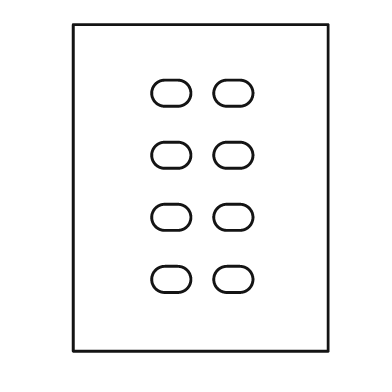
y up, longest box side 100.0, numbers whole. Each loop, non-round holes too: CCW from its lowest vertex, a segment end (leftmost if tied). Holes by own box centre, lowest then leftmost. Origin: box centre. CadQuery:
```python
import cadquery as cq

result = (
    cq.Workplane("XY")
    .moveTo(-39.0, -50.0)
    .lineTo(39.0, -50.0)
    .lineTo(39.0, 50.0)
    .lineTo(-39.0, 50.0)
    .close()
    .moveTo(-11.0, -32.0)
    .lineTo(-7.0, -32.0)
    .threePointArc((-3.0, -28.0), (-7.0, -24.0))
    .lineTo(-11.0, -24.0)
    .threePointArc((-15.0, -28.0), (-11.0, -32.0))
    .close()
    .moveTo(8.0, -32.0)
    .lineTo(12.0, -32.0)
    .threePointArc((16.0, -28.0), (12.0, -24.0))
    .lineTo(8.0, -24.0)
    .threePointArc((4.0, -28.0), (8.0, -32.0))
    .close()
    .moveTo(-11.0, -13.0)
    .lineTo(-7.0, -13.0)
    .threePointArc((-3.0, -9.0), (-7.0, -5.0))
    .lineTo(-11.0, -5.0)
    .threePointArc((-15.0, -9.0), (-11.0, -13.0))
    .close()
    .moveTo(8.0, -13.0)
    .lineTo(12.0, -13.0)
    .threePointArc((16.0, -9.0), (12.0, -5.0))
    .lineTo(8.0, -5.0)
    .threePointArc((4.0, -9.0), (8.0, -13.0))
    .close()
    .moveTo(-11.0, 6.0)
    .lineTo(-7.0, 6.0)
    .threePointArc((-3.0, 10.0), (-7.0, 14.0))
    .lineTo(-11.0, 14.0)
    .threePointArc((-15.0, 10.0), (-11.0, 6.0))
    .close()
    .moveTo(8.0, 6.0)
    .lineTo(12.0, 6.0)
    .threePointArc((16.0, 10.0), (12.0, 14.0))
    .lineTo(8.0, 14.0)
    .threePointArc((4.0, 10.0), (8.0, 6.0))
    .close()
    .moveTo(-11.0, 25.0)
    .lineTo(-7.0, 25.0)
    .threePointArc((-3.0, 29.0), (-7.0, 33.0))
    .lineTo(-11.0, 33.0)
    .threePointArc((-15.0, 29.0), (-11.0, 25.0))
    .close()
    .moveTo(8.0, 25.0)
    .lineTo(12.0, 25.0)
    .threePointArc((16.0, 29.0), (12.0, 33.0))
    .lineTo(8.0, 33.0)
    .threePointArc((4.0, 29.0), (8.0, 25.0))
    .close()
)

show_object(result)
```